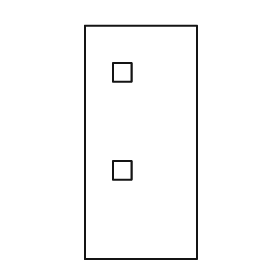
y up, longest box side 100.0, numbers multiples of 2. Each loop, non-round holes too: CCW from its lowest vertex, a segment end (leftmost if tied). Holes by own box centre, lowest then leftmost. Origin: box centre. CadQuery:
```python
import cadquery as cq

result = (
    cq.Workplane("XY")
    .moveTo(-24.0, -50.0)
    .lineTo(24.0, -50.0)
    .lineTo(24.0, 50.0)
    .lineTo(-24.0, 50.0)
    .close()
    .moveTo(-12.0, -16.0)
    .lineTo(-4.0, -16.0)
    .lineTo(-4.0, -8.0)
    .lineTo(-12.0, -8.0)
    .close()
    .moveTo(-12.0, 26.0)
    .lineTo(-4.0, 26.0)
    .lineTo(-4.0, 34.0)
    .lineTo(-12.0, 34.0)
    .close()
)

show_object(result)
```